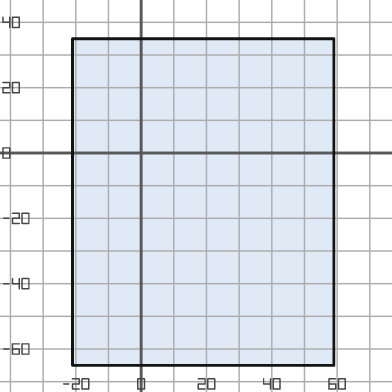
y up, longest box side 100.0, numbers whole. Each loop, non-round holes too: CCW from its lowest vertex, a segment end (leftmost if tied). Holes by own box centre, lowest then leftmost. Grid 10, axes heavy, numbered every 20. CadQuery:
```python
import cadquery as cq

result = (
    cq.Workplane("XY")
    .moveTo(-21.0, -65.0)
    .lineTo(59.0, -65.0)
    .lineTo(59.0, 35.0)
    .lineTo(-21.0, 35.0)
    .close()
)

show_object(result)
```